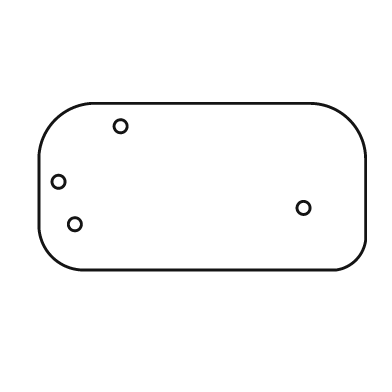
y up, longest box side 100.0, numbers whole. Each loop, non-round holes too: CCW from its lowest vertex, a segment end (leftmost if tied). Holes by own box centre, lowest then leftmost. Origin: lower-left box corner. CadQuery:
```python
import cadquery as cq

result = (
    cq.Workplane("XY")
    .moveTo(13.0, 0.0)
    .lineTo(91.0, 0.0)
    .threePointArc((97.0, 3.0), (100.0, 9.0))
    .lineTo(100.0, 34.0)
    .threePointArc((95.0, 46.0), (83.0, 51.0))
    .lineTo(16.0, 51.0)
    .threePointArc((5.0, 46.0), (0.0, 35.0))
    .lineTo(0.0, 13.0)
    .threePointArc((4.0, 4.0), (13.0, 0.0))
    .close()
    .moveTo(11.0, 14.0)
    .circle(2.0)
    .moveTo(81.0, 19.0)
    .circle(2.0)
    .moveTo(6.0, 27.0)
    .circle(2.0)
    .moveTo(25.0, 44.0)
    .circle(2.0)
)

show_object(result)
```